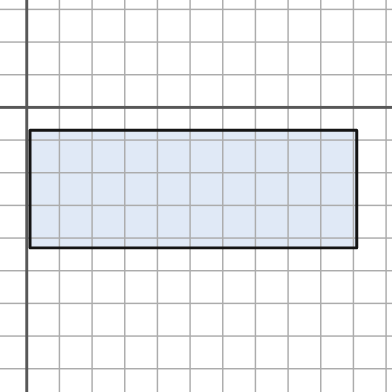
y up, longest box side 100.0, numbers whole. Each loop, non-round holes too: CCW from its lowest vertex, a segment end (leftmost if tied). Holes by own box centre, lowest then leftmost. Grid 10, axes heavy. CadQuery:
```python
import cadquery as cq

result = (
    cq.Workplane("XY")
    .moveTo(1.0, -43.0)
    .lineTo(101.0, -43.0)
    .lineTo(101.0, -7.0)
    .lineTo(1.0, -7.0)
    .close()
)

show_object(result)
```